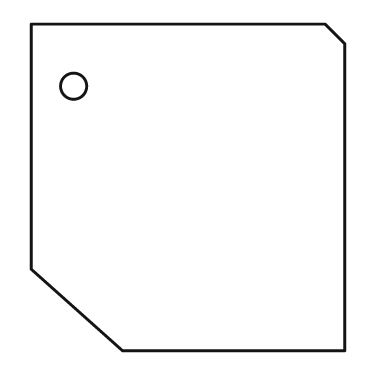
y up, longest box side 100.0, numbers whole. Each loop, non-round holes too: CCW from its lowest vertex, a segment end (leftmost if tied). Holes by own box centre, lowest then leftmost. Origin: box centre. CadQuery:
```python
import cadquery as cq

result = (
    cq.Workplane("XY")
    .moveTo(-20.0, -50.0)
    .lineTo(48.0, -50.0)
    .lineTo(48.0, 44.0)
    .lineTo(42.0, 50.0)
    .lineTo(-48.0, 50.0)
    .lineTo(-48.0, -25.0)
    .close()
    .moveTo(-35.0, 31.0)
    .circle(4.0)
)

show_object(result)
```